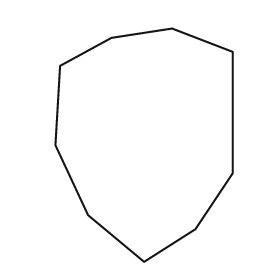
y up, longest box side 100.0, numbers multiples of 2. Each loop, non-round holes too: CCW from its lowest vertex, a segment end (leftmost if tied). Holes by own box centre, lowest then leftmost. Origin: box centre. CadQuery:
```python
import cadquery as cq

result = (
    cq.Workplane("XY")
    .moveTo(0.0, -50.0)
    .lineTo(22.0, -36.0)
    .lineTo(38.0, -12.0)
    .lineTo(38.0, 40.0)
    .lineTo(12.0, 50.0)
    .lineTo(-14.0, 46.0)
    .lineTo(-36.0, 34.0)
    .lineTo(-38.0, 0.0)
    .lineTo(-24.0, -30.0)
    .close()
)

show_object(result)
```